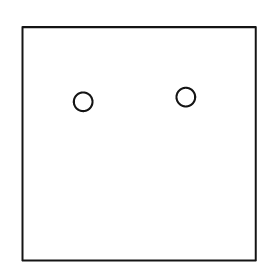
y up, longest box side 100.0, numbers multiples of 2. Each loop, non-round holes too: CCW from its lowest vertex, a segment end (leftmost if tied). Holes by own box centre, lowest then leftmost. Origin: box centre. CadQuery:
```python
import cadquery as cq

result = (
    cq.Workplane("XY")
    .moveTo(-50.0, -50.0)
    .lineTo(50.0, -50.0)
    .lineTo(50.0, 50.0)
    .lineTo(-50.0, 50.0)
    .close()
    .moveTo(-24.0, 18.0)
    .circle(4.0)
    .moveTo(20.0, 20.0)
    .circle(4.0)
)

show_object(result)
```